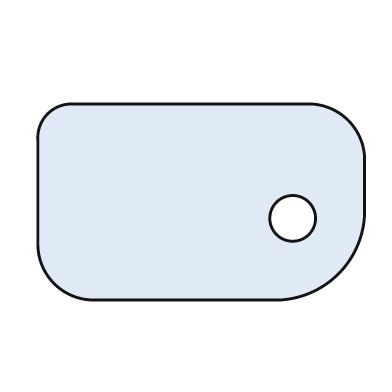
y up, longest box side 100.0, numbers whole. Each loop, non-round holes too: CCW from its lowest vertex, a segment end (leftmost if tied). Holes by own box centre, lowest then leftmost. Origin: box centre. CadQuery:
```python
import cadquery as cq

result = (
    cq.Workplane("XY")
    .moveTo(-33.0, -30.0)
    .lineTo(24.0, -30.0)
    .threePointArc((42.0, -22.0), (50.0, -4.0))
    .lineTo(50.0, 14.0)
    .threePointArc((45.0, 25.0), (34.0, 30.0))
    .lineTo(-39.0, 30.0)
    .threePointArc((-47.0, 27.0), (-50.0, 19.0))
    .lineTo(-50.0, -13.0)
    .threePointArc((-45.0, -25.0), (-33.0, -30.0))
    .close()
    .moveTo(28.0, -5.0)
    .circle(7.0)
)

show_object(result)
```